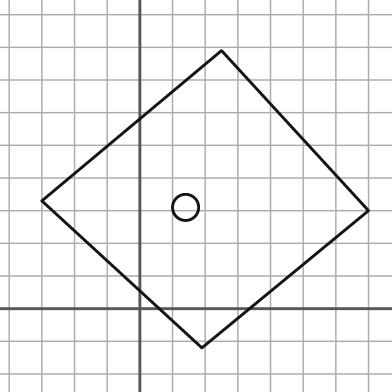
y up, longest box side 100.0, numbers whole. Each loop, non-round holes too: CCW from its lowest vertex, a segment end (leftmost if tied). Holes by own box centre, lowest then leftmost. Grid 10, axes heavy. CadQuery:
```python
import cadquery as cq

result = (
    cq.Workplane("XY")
    .moveTo(19.0, -12.0)
    .lineTo(70.0, 30.0)
    .lineTo(25.0, 79.0)
    .lineTo(-30.0, 33.0)
    .close()
    .moveTo(14.0, 31.0)
    .circle(4.0)
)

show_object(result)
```